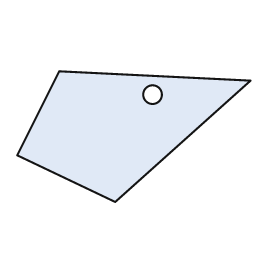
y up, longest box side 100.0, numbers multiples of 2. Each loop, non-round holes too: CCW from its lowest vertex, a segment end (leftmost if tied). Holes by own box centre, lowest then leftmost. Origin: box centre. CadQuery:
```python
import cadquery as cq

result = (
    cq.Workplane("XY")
    .moveTo(-8.0, -28.0)
    .lineTo(50.0, 24.0)
    .lineTo(-32.0, 28.0)
    .lineTo(-50.0, -8.0)
    .close()
    .moveTo(8.0, 18.0)
    .circle(4.0)
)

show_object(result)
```